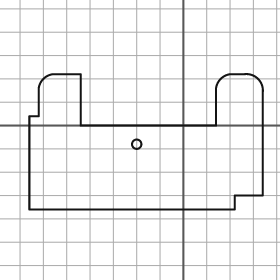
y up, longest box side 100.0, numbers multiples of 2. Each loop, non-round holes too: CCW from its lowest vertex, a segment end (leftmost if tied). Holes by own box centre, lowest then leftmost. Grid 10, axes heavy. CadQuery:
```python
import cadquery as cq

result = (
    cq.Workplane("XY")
    .moveTo(-66.0, -36.0)
    .lineTo(22.0, -36.0)
    .lineTo(22.0, -30.0)
    .lineTo(34.0, -30.0)
    .lineTo(34.0, 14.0)
    .threePointArc((32.0, 20.0), (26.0, 22.0))
    .lineTo(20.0, 22.0)
    .threePointArc((16.0, 20.0), (14.0, 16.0))
    .lineTo(14.0, 0.0)
    .lineTo(-44.0, 0.0)
    .lineTo(-44.0, 22.0)
    .lineTo(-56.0, 22.0)
    .threePointArc((-60.0, 20.0), (-62.0, 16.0))
    .lineTo(-62.0, 4.0)
    .lineTo(-66.0, 4.0)
    .close()
    .moveTo(-20.0, -8.0)
    .circle(2.0)
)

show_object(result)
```